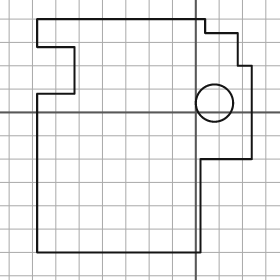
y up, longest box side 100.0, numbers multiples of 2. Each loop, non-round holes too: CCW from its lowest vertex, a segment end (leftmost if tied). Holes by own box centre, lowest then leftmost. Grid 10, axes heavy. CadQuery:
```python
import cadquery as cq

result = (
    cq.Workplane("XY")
    .moveTo(-68.0, -60.0)
    .lineTo(2.0, -60.0)
    .lineTo(2.0, -20.0)
    .lineTo(24.0, -20.0)
    .lineTo(24.0, 20.0)
    .lineTo(18.0, 20.0)
    .lineTo(18.0, 34.0)
    .lineTo(4.0, 34.0)
    .lineTo(4.0, 40.0)
    .lineTo(-68.0, 40.0)
    .lineTo(-68.0, 28.0)
    .lineTo(-52.0, 28.0)
    .lineTo(-52.0, 8.0)
    .lineTo(-68.0, 8.0)
    .close()
    .moveTo(8.0, 4.0)
    .circle(8.0)
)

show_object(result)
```